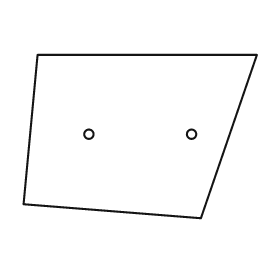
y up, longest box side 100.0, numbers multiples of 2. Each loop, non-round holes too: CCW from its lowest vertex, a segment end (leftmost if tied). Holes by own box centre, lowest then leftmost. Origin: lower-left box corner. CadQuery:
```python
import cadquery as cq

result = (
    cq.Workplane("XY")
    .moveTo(76.0, 0.0)
    .lineTo(100.0, 70.0)
    .lineTo(6.0, 70.0)
    .lineTo(0.0, 6.0)
    .close()
    .moveTo(28.0, 36.0)
    .circle(2.0)
    .moveTo(72.0, 36.0)
    .circle(2.0)
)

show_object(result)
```